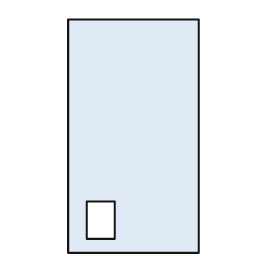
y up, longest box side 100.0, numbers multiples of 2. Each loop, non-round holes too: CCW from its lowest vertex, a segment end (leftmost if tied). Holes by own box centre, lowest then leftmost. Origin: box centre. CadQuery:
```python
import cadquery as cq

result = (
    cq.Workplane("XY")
    .moveTo(-28.0, -50.0)
    .lineTo(28.0, -50.0)
    .lineTo(28.0, 50.0)
    .lineTo(-28.0, 50.0)
    .close()
    .moveTo(-20.0, -44.0)
    .lineTo(-8.0, -44.0)
    .lineTo(-8.0, -28.0)
    .lineTo(-20.0, -28.0)
    .close()
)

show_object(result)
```